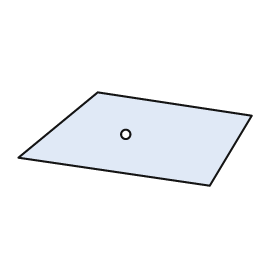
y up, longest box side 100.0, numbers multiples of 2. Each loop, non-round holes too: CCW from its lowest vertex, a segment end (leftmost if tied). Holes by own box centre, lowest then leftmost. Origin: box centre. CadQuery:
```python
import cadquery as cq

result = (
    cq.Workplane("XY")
    .moveTo(32.0, -20.0)
    .lineTo(50.0, 10.0)
    .lineTo(-16.0, 20.0)
    .lineTo(-50.0, -8.0)
    .close()
    .moveTo(-4.0, 2.0)
    .circle(2.0)
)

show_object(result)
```